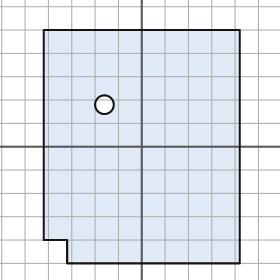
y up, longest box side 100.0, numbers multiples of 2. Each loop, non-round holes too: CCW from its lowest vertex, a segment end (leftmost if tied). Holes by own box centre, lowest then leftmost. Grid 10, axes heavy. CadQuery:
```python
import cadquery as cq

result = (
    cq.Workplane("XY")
    .moveTo(-32.0, -50.0)
    .lineTo(42.0, -50.0)
    .lineTo(42.0, 50.0)
    .lineTo(-42.0, 50.0)
    .lineTo(-42.0, -40.0)
    .lineTo(-32.0, -40.0)
    .close()
    .moveTo(-16.0, 18.0)
    .circle(4.0)
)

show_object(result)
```